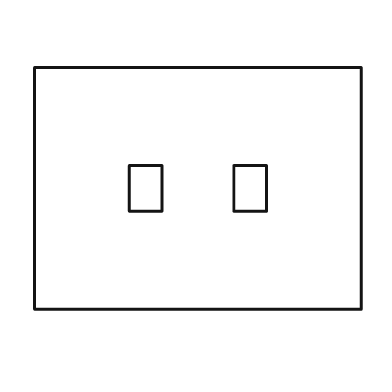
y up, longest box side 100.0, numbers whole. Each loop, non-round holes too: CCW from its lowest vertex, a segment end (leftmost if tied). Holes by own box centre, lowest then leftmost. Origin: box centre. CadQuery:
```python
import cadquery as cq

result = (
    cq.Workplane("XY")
    .moveTo(-50.0, -37.0)
    .lineTo(50.0, -37.0)
    .lineTo(50.0, 37.0)
    .lineTo(-50.0, 37.0)
    .close()
    .moveTo(-21.0, -7.0)
    .lineTo(-11.0, -7.0)
    .lineTo(-11.0, 7.0)
    .lineTo(-21.0, 7.0)
    .close()
    .moveTo(11.0, -7.0)
    .lineTo(21.0, -7.0)
    .lineTo(21.0, 7.0)
    .lineTo(11.0, 7.0)
    .close()
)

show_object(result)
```